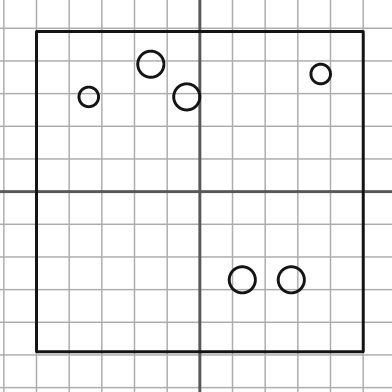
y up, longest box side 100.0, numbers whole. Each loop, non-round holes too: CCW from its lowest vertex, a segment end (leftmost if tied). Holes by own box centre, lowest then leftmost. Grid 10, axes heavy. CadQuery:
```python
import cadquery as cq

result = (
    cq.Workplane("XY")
    .moveTo(-50.0, -49.0)
    .lineTo(50.0, -49.0)
    .lineTo(50.0, 49.0)
    .lineTo(-50.0, 49.0)
    .close()
    .moveTo(13.0, -27.0)
    .circle(4.0)
    .moveTo(28.0, -27.0)
    .circle(4.0)
    .moveTo(-34.0, 29.0)
    .circle(3.0)
    .moveTo(-4.0, 29.0)
    .circle(4.0)
    .moveTo(37.0, 36.0)
    .circle(3.0)
    .moveTo(-15.0, 39.0)
    .circle(4.0)
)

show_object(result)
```